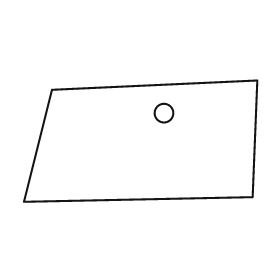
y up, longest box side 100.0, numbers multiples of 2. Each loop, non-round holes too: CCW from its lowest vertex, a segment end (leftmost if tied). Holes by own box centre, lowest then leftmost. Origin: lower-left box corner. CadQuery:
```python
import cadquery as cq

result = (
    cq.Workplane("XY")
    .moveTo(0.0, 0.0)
    .lineTo(98.0, 2.0)
    .lineTo(100.0, 52.0)
    .lineTo(12.0, 48.0)
    .close()
    .moveTo(60.0, 38.0)
    .circle(4.0)
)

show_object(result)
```